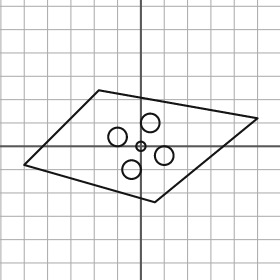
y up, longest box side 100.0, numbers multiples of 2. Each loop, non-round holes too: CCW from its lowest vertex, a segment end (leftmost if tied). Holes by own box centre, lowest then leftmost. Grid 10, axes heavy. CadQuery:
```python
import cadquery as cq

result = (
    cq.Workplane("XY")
    .moveTo(6.0, -24.0)
    .lineTo(50.0, 12.0)
    .lineTo(-18.0, 24.0)
    .lineTo(-50.0, -8.0)
    .close()
    .moveTo(-4.0, -10.0)
    .circle(4.0)
    .moveTo(10.0, -4.0)
    .circle(4.0)
    .moveTo(0.0, 0.0)
    .circle(2.0)
    .moveTo(-10.0, 4.0)
    .circle(4.0)
    .moveTo(4.0, 10.0)
    .circle(4.0)
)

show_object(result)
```